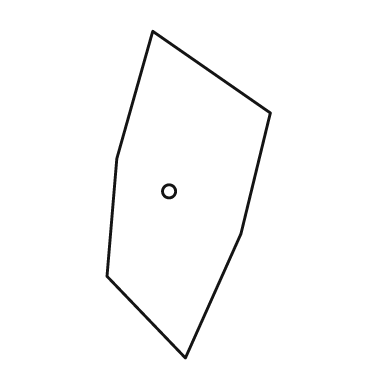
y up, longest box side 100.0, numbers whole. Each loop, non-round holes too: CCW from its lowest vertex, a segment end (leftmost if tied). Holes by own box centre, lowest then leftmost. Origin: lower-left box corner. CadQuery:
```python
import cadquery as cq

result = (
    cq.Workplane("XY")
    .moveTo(24.0, 0.0)
    .lineTo(41.0, 38.0)
    .lineTo(50.0, 75.0)
    .lineTo(14.0, 100.0)
    .lineTo(3.0, 61.0)
    .lineTo(0.0, 25.0)
    .close()
    .moveTo(19.0, 51.0)
    .circle(2.0)
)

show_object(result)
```